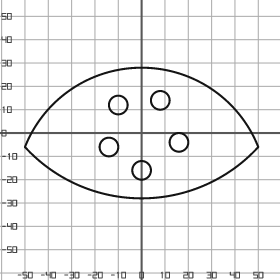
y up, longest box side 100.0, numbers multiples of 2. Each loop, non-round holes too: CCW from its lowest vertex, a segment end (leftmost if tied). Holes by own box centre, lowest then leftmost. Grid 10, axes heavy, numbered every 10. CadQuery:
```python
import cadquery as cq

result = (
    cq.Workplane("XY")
    .moveTo(-50.0, -6.0)
    .threePointArc((0.0, -28.0), (50.0, -6.0))
    .threePointArc((0.0, 28.0), (-50.0, -6.0))
    .close()
    .moveTo(0.0, -16.0)
    .circle(4.0)
    .moveTo(-14.0, -6.0)
    .circle(4.0)
    .moveTo(16.0, -4.0)
    .circle(4.0)
    .moveTo(-10.0, 12.0)
    .circle(4.0)
    .moveTo(8.0, 14.0)
    .circle(4.0)
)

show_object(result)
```